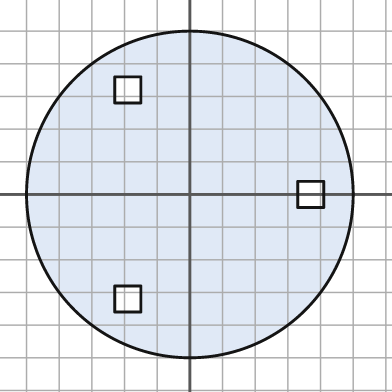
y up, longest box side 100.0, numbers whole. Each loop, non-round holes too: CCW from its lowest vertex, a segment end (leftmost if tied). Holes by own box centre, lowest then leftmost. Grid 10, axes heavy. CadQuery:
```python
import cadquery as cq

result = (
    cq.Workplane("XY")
    .moveTo(0.0, 0.0)
    .circle(50.0)
    .moveTo(-23.0, -36.0)
    .lineTo(-15.0, -36.0)
    .lineTo(-15.0, -28.0)
    .lineTo(-23.0, -28.0)
    .close()
    .moveTo(33.0, -4.0)
    .lineTo(41.0, -4.0)
    .lineTo(41.0, 4.0)
    .lineTo(33.0, 4.0)
    .close()
    .moveTo(-23.0, 28.0)
    .lineTo(-15.0, 28.0)
    .lineTo(-15.0, 36.0)
    .lineTo(-23.0, 36.0)
    .close()
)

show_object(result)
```